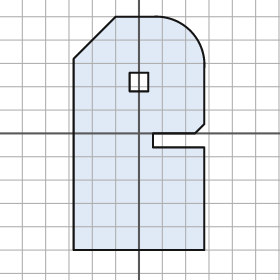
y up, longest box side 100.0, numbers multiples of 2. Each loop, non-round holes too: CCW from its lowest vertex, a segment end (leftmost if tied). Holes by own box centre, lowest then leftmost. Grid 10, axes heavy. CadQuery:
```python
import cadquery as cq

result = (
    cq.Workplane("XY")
    .moveTo(-28.0, -50.0)
    .lineTo(28.0, -50.0)
    .lineTo(28.0, -6.0)
    .lineTo(6.0, -6.0)
    .lineTo(6.0, 0.0)
    .lineTo(24.0, 0.0)
    .lineTo(28.0, 4.0)
    .lineTo(28.0, 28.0)
    .threePointArc((22.0, 44.0), (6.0, 50.0))
    .lineTo(-10.0, 50.0)
    .lineTo(-28.0, 32.0)
    .close()
    .moveTo(-4.0, 18.0)
    .lineTo(4.0, 18.0)
    .lineTo(4.0, 26.0)
    .lineTo(-4.0, 26.0)
    .close()
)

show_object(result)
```